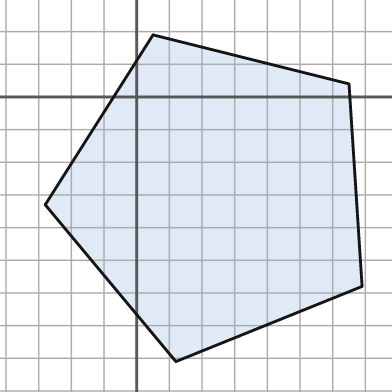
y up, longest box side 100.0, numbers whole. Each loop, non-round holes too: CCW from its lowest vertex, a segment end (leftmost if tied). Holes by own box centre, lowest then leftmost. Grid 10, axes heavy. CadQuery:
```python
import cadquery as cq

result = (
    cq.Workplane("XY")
    .moveTo(12.0, -81.0)
    .lineTo(69.0, -58.0)
    .lineTo(65.0, 4.0)
    .lineTo(5.0, 19.0)
    .lineTo(-28.0, -33.0)
    .close()
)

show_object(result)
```